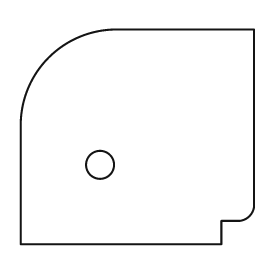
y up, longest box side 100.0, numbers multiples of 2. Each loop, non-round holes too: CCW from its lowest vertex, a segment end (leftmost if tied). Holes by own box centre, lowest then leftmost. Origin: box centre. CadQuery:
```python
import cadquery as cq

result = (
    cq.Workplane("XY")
    .moveTo(-50.0, -46.0)
    .lineTo(36.0, -46.0)
    .lineTo(36.0, -36.0)
    .lineTo(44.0, -36.0)
    .threePointArc((48.0, -34.0), (50.0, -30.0))
    .lineTo(50.0, 46.0)
    .lineTo(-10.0, 46.0)
    .threePointArc((-38.0, 34.0), (-50.0, 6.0))
    .close()
    .moveTo(-16.0, -12.0)
    .circle(6.0)
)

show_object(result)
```